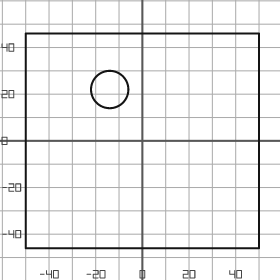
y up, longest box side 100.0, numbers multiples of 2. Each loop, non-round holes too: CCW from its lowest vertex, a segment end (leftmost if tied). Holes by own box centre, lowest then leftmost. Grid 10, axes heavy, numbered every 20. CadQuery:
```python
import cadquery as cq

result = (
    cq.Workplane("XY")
    .moveTo(-50.0, -46.0)
    .lineTo(50.0, -46.0)
    .lineTo(50.0, 46.0)
    .lineTo(-50.0, 46.0)
    .close()
    .moveTo(-14.0, 22.0)
    .circle(8.0)
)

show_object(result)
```